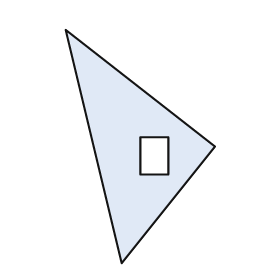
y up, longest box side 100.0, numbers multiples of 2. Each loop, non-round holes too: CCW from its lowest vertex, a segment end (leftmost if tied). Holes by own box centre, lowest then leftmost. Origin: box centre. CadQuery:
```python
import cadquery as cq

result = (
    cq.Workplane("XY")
    .moveTo(-8.0, -50.0)
    .lineTo(32.0, 0.0)
    .lineTo(-32.0, 50.0)
    .close()
    .moveTo(0.0, -12.0)
    .lineTo(12.0, -12.0)
    .lineTo(12.0, 4.0)
    .lineTo(0.0, 4.0)
    .close()
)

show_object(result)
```